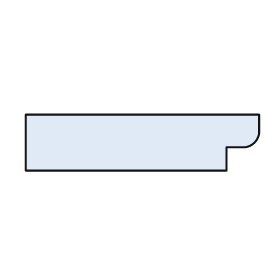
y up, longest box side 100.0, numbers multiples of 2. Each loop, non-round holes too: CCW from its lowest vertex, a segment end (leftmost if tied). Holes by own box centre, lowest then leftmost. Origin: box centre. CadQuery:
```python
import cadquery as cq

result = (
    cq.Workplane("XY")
    .moveTo(-50.0, -12.0)
    .lineTo(36.0, -12.0)
    .lineTo(36.0, -2.0)
    .lineTo(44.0, -2.0)
    .threePointArc((48.0, 0.0), (50.0, 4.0))
    .lineTo(50.0, 12.0)
    .lineTo(-50.0, 12.0)
    .close()
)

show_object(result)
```